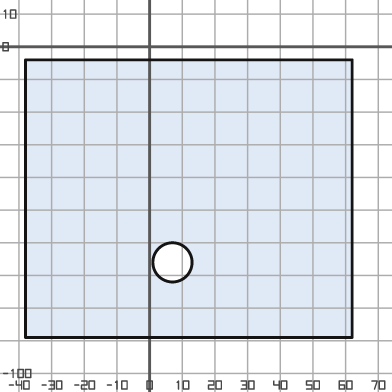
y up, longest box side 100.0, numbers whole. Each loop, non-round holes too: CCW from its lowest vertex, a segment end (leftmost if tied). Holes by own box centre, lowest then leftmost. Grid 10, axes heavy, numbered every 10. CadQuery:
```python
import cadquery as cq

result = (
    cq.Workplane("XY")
    .moveTo(-38.0, -89.0)
    .lineTo(62.0, -89.0)
    .lineTo(62.0, -4.0)
    .lineTo(-38.0, -4.0)
    .close()
    .moveTo(7.0, -66.0)
    .circle(6.0)
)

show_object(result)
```